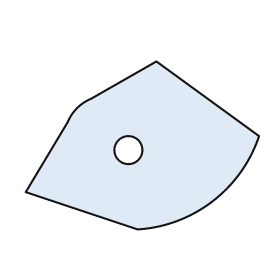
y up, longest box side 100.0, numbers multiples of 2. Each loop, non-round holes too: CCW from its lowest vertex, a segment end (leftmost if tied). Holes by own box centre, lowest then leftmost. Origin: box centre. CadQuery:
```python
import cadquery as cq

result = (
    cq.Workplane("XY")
    .moveTo(-2.0, -36.0)
    .threePointArc((30.0, -24.0), (50.0, 4.0))
    .lineTo(6.0, 36.0)
    .lineTo(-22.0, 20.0)
    .threePointArc((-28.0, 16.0), (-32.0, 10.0))
    .lineTo(-50.0, -20.0)
    .close()
    .moveTo(-6.0, -2.0)
    .circle(6.0)
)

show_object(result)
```